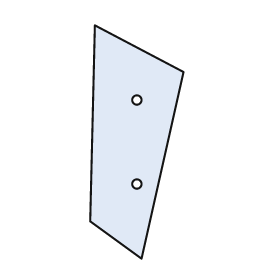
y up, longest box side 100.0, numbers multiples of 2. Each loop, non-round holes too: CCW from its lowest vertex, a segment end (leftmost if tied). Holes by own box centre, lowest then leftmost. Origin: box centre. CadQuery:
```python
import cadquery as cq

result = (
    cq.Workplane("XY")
    .moveTo(2.0, -50.0)
    .lineTo(20.0, 30.0)
    .lineTo(-18.0, 50.0)
    .lineTo(-20.0, -34.0)
    .close()
    .moveTo(0.0, -18.0)
    .circle(2.0)
    .moveTo(0.0, 18.0)
    .circle(2.0)
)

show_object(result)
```